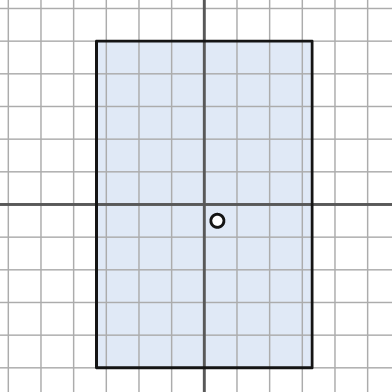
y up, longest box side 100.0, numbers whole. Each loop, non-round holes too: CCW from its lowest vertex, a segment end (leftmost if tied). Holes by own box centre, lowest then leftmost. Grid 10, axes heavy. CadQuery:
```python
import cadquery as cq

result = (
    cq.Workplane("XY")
    .moveTo(-33.0, -50.0)
    .lineTo(33.0, -50.0)
    .lineTo(33.0, 50.0)
    .lineTo(-33.0, 50.0)
    .close()
    .moveTo(4.0, -5.0)
    .circle(2.0)
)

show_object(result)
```